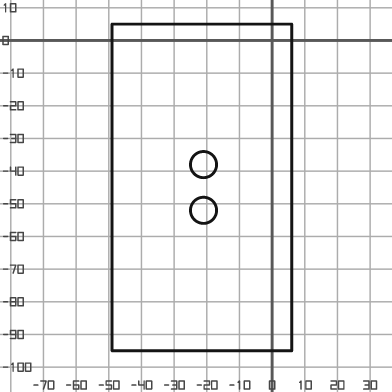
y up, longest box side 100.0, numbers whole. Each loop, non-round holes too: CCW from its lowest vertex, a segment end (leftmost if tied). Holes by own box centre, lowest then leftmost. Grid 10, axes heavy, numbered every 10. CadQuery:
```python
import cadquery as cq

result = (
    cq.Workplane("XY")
    .moveTo(-49.0, -95.0)
    .lineTo(6.0, -95.0)
    .lineTo(6.0, 5.0)
    .lineTo(-49.0, 5.0)
    .close()
    .moveTo(-21.0, -52.0)
    .circle(4.0)
    .moveTo(-21.0, -38.0)
    .circle(4.0)
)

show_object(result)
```